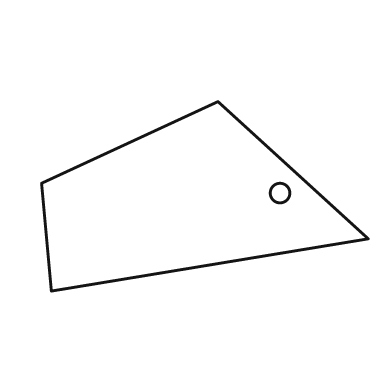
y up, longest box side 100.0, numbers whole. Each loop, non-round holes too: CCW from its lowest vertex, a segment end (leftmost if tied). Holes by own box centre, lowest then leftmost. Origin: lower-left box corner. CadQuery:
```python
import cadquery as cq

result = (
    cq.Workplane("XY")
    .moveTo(3.0, 0.0)
    .lineTo(100.0, 16.0)
    .lineTo(54.0, 58.0)
    .lineTo(0.0, 33.0)
    .close()
    .moveTo(73.0, 30.0)
    .circle(3.0)
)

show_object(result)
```